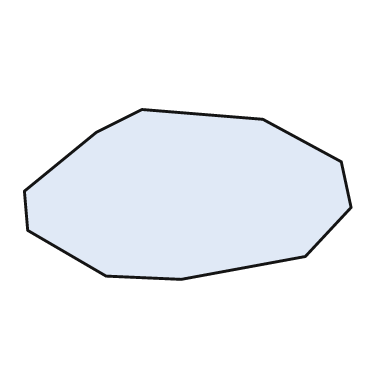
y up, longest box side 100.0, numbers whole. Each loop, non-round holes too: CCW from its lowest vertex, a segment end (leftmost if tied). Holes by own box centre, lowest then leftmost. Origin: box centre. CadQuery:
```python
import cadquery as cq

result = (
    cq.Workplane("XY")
    .moveTo(-2.0, -26.0)
    .lineTo(36.0, -19.0)
    .lineTo(50.0, -4.0)
    .lineTo(47.0, 10.0)
    .lineTo(23.0, 23.0)
    .lineTo(-14.0, 26.0)
    .lineTo(-28.0, 19.0)
    .lineTo(-50.0, 1.0)
    .lineTo(-49.0, -11.0)
    .lineTo(-25.0, -25.0)
    .close()
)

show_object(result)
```